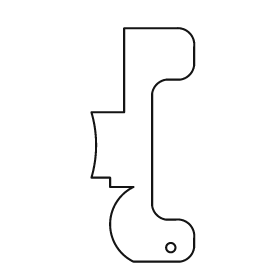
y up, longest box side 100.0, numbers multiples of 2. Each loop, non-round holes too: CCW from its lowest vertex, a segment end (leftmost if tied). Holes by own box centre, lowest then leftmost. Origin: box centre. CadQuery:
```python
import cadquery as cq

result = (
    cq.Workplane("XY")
    .moveTo(-4.0, -50.0)
    .lineTo(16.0, -50.0)
    .threePointArc((20.0, -48.0), (22.0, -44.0))
    .lineTo(22.0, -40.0)
    .threePointArc((20.0, -34.0), (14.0, -32.0))
    .lineTo(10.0, -32.0)
    .threePointArc((6.0, -30.0), (4.0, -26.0))
    .lineTo(4.0, 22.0)
    .threePointArc((6.0, 26.0), (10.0, 28.0))
    .lineTo(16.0, 28.0)
    .threePointArc((20.0, 30.0), (22.0, 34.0))
    .lineTo(22.0, 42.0)
    .threePointArc((20.0, 48.0), (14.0, 50.0))
    .lineTo(-8.0, 50.0)
    .lineTo(-8.0, 14.0)
    .lineTo(-22.0, 14.0)
    .threePointArc((-20.0, 0.0), (-22.0, -14.0))
    .lineTo(-14.0, -14.0)
    .lineTo(-14.0, -18.0)
    .lineTo(-4.0, -18.0)
    .threePointArc((-14.0, -34.0), (-4.0, -50.0))
    .close()
    .moveTo(12.0, -44.0)
    .circle(2.0)
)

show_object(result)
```